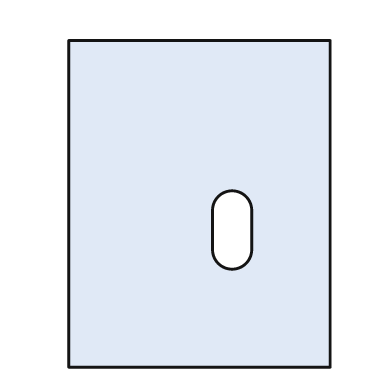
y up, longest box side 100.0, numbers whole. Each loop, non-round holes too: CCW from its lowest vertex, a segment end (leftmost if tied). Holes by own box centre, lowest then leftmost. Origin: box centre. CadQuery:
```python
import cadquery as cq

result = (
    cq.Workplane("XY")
    .moveTo(-40.0, -50.0)
    .lineTo(40.0, -50.0)
    .lineTo(40.0, 50.0)
    .lineTo(-40.0, 50.0)
    .close()
    .moveTo(4.0, -14.0)
    .threePointArc((10.0, -20.0), (16.0, -14.0))
    .lineTo(16.0, -2.0)
    .threePointArc((10.0, 4.0), (4.0, -2.0))
    .close()
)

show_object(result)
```